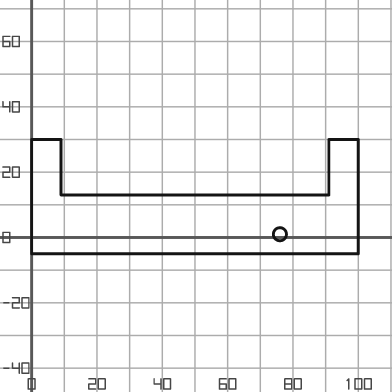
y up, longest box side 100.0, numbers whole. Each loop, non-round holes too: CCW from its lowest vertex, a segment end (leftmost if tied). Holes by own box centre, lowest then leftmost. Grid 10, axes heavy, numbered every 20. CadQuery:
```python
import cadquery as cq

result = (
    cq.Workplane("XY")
    .moveTo(0.0, -5.0)
    .lineTo(100.0, -5.0)
    .lineTo(100.0, 30.0)
    .lineTo(91.0, 30.0)
    .lineTo(91.0, 13.0)
    .lineTo(9.0, 13.0)
    .lineTo(9.0, 30.0)
    .lineTo(0.0, 30.0)
    .close()
    .moveTo(76.0, 1.0)
    .circle(2.0)
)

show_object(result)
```